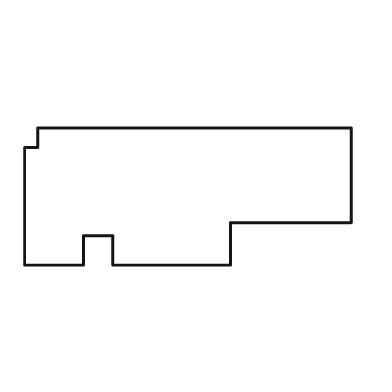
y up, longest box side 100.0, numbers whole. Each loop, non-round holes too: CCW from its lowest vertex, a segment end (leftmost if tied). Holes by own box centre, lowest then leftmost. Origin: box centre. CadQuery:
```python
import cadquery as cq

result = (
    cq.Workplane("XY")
    .moveTo(-50.0, -21.0)
    .lineTo(-32.0, -21.0)
    .lineTo(-32.0, -12.0)
    .lineTo(-23.0, -12.0)
    .lineTo(-23.0, -21.0)
    .lineTo(13.0, -21.0)
    .lineTo(13.0, -8.0)
    .lineTo(50.0, -8.0)
    .lineTo(50.0, 21.0)
    .lineTo(-46.0, 21.0)
    .lineTo(-46.0, 15.0)
    .lineTo(-50.0, 15.0)
    .close()
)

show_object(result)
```